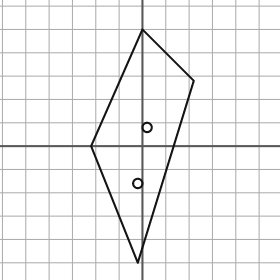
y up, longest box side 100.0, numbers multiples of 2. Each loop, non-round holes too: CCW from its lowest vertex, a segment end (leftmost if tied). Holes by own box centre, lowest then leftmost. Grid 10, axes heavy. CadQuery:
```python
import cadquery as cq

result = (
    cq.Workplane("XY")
    .moveTo(-2.0, -50.0)
    .lineTo(22.0, 28.0)
    .lineTo(0.0, 50.0)
    .lineTo(-22.0, 0.0)
    .close()
    .moveTo(-2.0, -16.0)
    .circle(2.0)
    .moveTo(2.0, 8.0)
    .circle(2.0)
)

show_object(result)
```